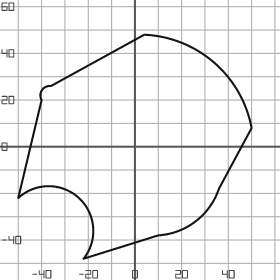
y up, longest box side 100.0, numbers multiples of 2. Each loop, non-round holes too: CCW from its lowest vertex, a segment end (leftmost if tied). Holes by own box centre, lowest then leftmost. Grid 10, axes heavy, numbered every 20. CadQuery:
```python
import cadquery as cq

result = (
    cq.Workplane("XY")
    .moveTo(-22.0, -48.0)
    .lineTo(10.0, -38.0)
    .threePointArc((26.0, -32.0), (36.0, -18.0))
    .lineTo(50.0, 8.0)
    .threePointArc((34.0, 36.0), (4.0, 48.0))
    .lineTo(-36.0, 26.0)
    .threePointArc((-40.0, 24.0), (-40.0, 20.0))
    .lineTo(-50.0, -22.0)
    .threePointArc((-24.0, -22.0), (-22.0, -48.0))
    .close()
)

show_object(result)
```